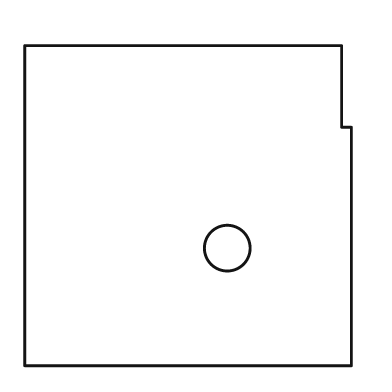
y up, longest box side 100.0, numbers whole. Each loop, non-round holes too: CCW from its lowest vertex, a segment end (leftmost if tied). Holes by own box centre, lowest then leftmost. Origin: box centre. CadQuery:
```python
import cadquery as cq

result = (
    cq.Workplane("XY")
    .moveTo(-50.0, -49.0)
    .lineTo(50.0, -49.0)
    .lineTo(50.0, 24.0)
    .lineTo(47.0, 24.0)
    .lineTo(47.0, 49.0)
    .lineTo(-50.0, 49.0)
    .close()
    .moveTo(12.0, -13.0)
    .circle(7.0)
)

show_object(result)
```